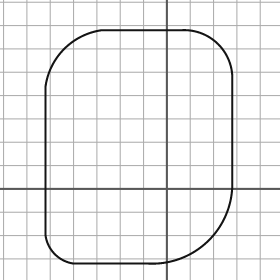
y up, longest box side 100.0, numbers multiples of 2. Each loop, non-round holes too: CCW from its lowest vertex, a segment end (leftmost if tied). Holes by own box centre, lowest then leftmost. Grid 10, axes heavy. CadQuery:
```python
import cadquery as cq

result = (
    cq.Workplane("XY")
    .moveTo(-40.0, -32.0)
    .lineTo(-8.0, -32.0)
    .threePointArc((18.0, -22.0), (28.0, 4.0))
    .lineTo(28.0, 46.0)
    .threePointArc((22.0, 62.0), (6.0, 68.0))
    .lineTo(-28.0, 68.0)
    .threePointArc((-44.0, 60.0), (-52.0, 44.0))
    .lineTo(-52.0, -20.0)
    .threePointArc((-48.0, -28.0), (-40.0, -32.0))
    .close()
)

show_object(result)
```